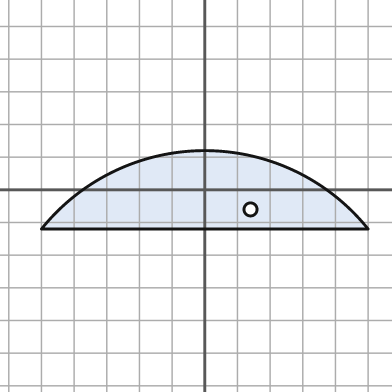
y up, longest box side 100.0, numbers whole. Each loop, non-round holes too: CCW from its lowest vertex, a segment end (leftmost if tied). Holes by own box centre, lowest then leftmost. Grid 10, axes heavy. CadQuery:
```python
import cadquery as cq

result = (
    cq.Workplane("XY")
    .moveTo(-50.0, -12.0)
    .lineTo(50.0, -12.0)
    .threePointArc((0.0, 12.0), (-50.0, -12.0))
    .close()
    .moveTo(14.0, -6.0)
    .circle(2.0)
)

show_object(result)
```